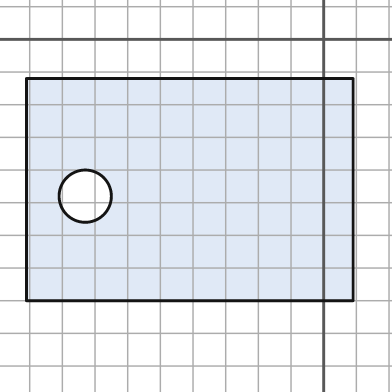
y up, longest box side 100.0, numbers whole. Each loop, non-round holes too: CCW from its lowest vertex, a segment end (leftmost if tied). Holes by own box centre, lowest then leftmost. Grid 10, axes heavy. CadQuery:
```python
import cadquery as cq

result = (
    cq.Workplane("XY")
    .moveTo(-91.0, -80.0)
    .lineTo(9.0, -80.0)
    .lineTo(9.0, -12.0)
    .lineTo(-91.0, -12.0)
    .close()
    .moveTo(-73.0, -48.0)
    .circle(8.0)
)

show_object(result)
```